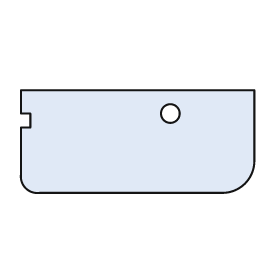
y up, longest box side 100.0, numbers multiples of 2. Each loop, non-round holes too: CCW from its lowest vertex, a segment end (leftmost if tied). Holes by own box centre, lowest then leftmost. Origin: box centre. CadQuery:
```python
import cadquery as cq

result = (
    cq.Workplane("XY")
    .moveTo(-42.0, -22.0)
    .lineTo(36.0, -22.0)
    .threePointArc((46.0, -18.0), (50.0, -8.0))
    .lineTo(50.0, 22.0)
    .lineTo(-50.0, 22.0)
    .lineTo(-50.0, 12.0)
    .lineTo(-46.0, 12.0)
    .lineTo(-46.0, 6.0)
    .lineTo(-50.0, 6.0)
    .lineTo(-50.0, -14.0)
    .threePointArc((-48.0, -20.0), (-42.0, -22.0))
    .close()
    .moveTo(14.0, 12.0)
    .circle(4.0)
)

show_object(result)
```